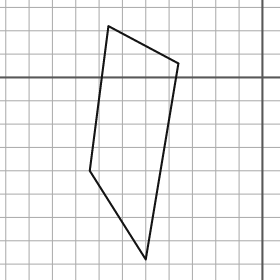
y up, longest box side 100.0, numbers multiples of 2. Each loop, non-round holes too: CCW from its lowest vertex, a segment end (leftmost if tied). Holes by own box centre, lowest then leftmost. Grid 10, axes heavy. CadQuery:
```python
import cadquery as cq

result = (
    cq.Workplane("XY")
    .moveTo(-50.0, -78.0)
    .lineTo(-36.0, 6.0)
    .lineTo(-66.0, 22.0)
    .lineTo(-74.0, -40.0)
    .close()
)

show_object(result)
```